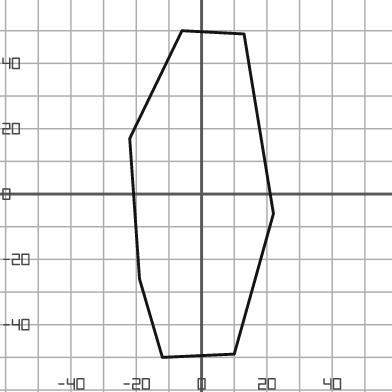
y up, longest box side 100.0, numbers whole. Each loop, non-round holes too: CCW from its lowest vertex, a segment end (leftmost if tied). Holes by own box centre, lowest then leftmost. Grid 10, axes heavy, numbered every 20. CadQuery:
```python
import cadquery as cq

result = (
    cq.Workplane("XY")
    .moveTo(-12.0, -50.0)
    .lineTo(10.0, -49.0)
    .lineTo(22.0, -6.0)
    .lineTo(13.0, 49.0)
    .lineTo(-6.0, 50.0)
    .lineTo(-22.0, 17.0)
    .lineTo(-19.0, -26.0)
    .close()
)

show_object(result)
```